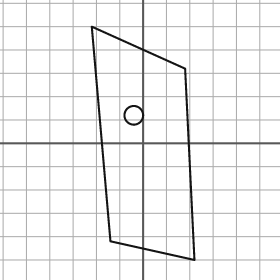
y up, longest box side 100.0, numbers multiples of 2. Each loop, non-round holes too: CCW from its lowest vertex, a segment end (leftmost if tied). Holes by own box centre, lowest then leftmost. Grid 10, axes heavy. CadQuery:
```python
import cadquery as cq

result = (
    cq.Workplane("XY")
    .moveTo(22.0, -50.0)
    .lineTo(18.0, 32.0)
    .lineTo(-22.0, 50.0)
    .lineTo(-14.0, -42.0)
    .close()
    .moveTo(-4.0, 12.0)
    .circle(4.0)
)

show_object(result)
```